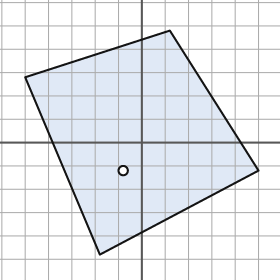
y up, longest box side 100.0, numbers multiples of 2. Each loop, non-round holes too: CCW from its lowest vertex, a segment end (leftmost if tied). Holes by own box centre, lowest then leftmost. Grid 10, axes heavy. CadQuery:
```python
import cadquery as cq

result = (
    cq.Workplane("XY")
    .moveTo(-18.0, -48.0)
    .lineTo(50.0, -12.0)
    .lineTo(12.0, 48.0)
    .lineTo(-50.0, 28.0)
    .close()
    .moveTo(-8.0, -12.0)
    .circle(2.0)
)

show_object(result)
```